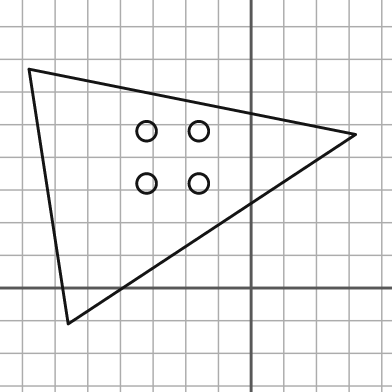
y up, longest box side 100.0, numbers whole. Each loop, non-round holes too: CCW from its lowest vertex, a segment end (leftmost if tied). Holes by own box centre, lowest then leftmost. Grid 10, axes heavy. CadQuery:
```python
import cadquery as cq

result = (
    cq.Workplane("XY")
    .moveTo(-56.0, -11.0)
    .lineTo(32.0, 47.0)
    .lineTo(-68.0, 67.0)
    .close()
    .moveTo(-32.0, 32.0)
    .circle(3.0)
    .moveTo(-16.0, 32.0)
    .circle(3.0)
    .moveTo(-32.0, 48.0)
    .circle(3.0)
    .moveTo(-16.0, 48.0)
    .circle(3.0)
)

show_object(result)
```